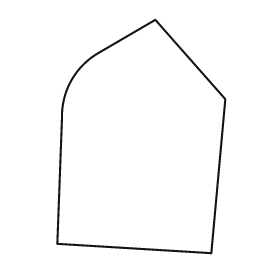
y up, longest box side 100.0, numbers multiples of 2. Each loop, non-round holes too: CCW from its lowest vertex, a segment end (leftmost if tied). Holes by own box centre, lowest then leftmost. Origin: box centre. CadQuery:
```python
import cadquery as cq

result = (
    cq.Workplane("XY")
    .moveTo(30.0, -50.0)
    .lineTo(36.0, 16.0)
    .lineTo(6.0, 50.0)
    .lineTo(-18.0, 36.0)
    .threePointArc((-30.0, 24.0), (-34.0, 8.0))
    .lineTo(-36.0, -46.0)
    .close()
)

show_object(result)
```